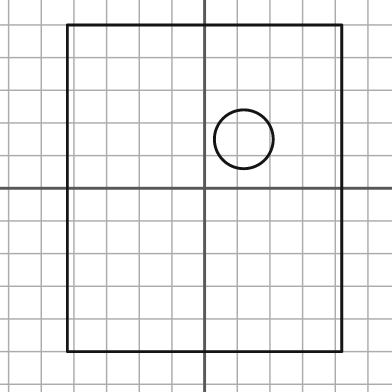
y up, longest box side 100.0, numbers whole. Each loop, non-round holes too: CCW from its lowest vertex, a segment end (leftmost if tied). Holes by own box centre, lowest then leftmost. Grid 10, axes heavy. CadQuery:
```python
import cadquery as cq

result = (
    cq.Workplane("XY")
    .moveTo(-42.0, -50.0)
    .lineTo(42.0, -50.0)
    .lineTo(42.0, 50.0)
    .lineTo(-42.0, 50.0)
    .close()
    .moveTo(12.0, 15.0)
    .circle(9.0)
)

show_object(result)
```